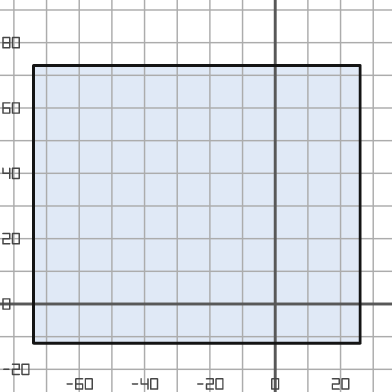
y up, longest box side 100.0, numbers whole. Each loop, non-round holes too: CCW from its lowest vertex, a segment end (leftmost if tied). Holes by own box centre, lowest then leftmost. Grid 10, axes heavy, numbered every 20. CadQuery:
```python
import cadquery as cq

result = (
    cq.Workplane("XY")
    .moveTo(-74.0, -12.0)
    .lineTo(26.0, -12.0)
    .lineTo(26.0, 73.0)
    .lineTo(-74.0, 73.0)
    .close()
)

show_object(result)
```